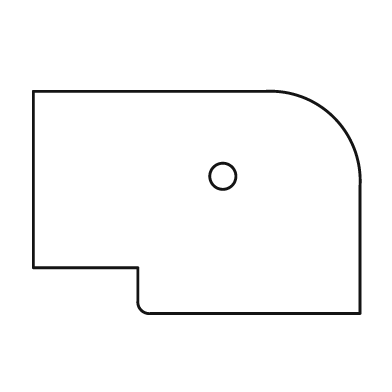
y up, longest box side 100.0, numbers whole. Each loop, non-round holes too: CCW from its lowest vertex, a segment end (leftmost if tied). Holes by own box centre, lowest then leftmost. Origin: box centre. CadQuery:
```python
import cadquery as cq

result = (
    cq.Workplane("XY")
    .moveTo(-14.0, -34.0)
    .lineTo(50.0, -34.0)
    .lineTo(50.0, 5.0)
    .threePointArc((42.0, 26.0), (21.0, 34.0))
    .lineTo(-50.0, 34.0)
    .lineTo(-50.0, -20.0)
    .lineTo(-18.0, -20.0)
    .lineTo(-18.0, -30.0)
    .threePointArc((-17.0, -33.0), (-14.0, -34.0))
    .close()
    .moveTo(8.0, 8.0)
    .circle(4.0)
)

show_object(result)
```